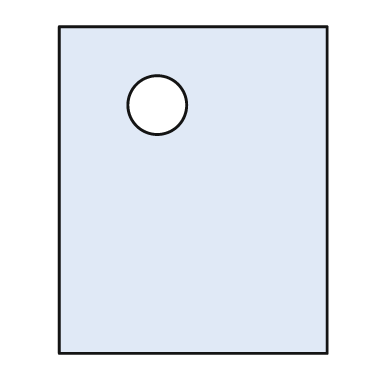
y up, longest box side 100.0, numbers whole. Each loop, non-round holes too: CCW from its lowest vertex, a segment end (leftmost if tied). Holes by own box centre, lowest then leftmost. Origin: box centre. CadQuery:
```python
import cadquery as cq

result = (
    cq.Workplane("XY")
    .moveTo(-41.0, -50.0)
    .lineTo(41.0, -50.0)
    .lineTo(41.0, 50.0)
    .lineTo(-41.0, 50.0)
    .close()
    .moveTo(-11.0, 26.0)
    .circle(9.0)
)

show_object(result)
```